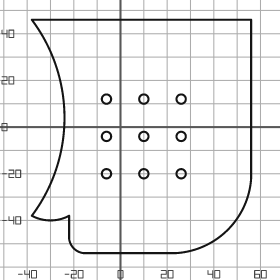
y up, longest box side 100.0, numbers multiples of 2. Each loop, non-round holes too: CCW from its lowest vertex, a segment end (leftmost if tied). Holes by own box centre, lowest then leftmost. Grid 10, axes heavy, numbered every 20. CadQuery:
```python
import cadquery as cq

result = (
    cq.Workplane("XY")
    .moveTo(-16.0, -54.0)
    .lineTo(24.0, -54.0)
    .threePointArc((46.0, -44.0), (56.0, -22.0))
    .lineTo(56.0, 46.0)
    .lineTo(-38.0, 46.0)
    .threePointArc((-24.0, 4.0), (-38.0, -38.0))
    .threePointArc((-30.0, -40.0), (-22.0, -38.0))
    .lineTo(-22.0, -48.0)
    .threePointArc((-20.0, -52.0), (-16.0, -54.0))
    .close()
    .moveTo(-6.0, -20.0)
    .circle(2.0)
    .moveTo(10.0, -20.0)
    .circle(2.0)
    .moveTo(26.0, -20.0)
    .circle(2.0)
    .moveTo(-6.0, -4.0)
    .circle(2.0)
    .moveTo(10.0, -4.0)
    .circle(2.0)
    .moveTo(26.0, -4.0)
    .circle(2.0)
    .moveTo(-6.0, 12.0)
    .circle(2.0)
    .moveTo(10.0, 12.0)
    .circle(2.0)
    .moveTo(26.0, 12.0)
    .circle(2.0)
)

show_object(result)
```